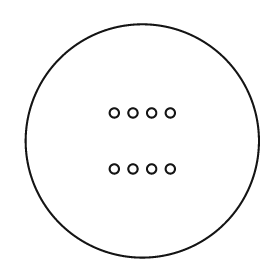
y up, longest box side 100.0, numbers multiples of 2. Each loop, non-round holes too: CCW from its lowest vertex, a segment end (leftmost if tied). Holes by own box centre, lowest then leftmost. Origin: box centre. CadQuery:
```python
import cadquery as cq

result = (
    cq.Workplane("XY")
    .moveTo(0.0, 0.0)
    .circle(50.0)
    .moveTo(-12.0, -12.0)
    .circle(2.0)
    .moveTo(-4.0, -12.0)
    .circle(2.0)
    .moveTo(4.0, -12.0)
    .circle(2.0)
    .moveTo(12.0, -12.0)
    .circle(2.0)
    .moveTo(-12.0, 12.0)
    .circle(2.0)
    .moveTo(-4.0, 12.0)
    .circle(2.0)
    .moveTo(4.0, 12.0)
    .circle(2.0)
    .moveTo(12.0, 12.0)
    .circle(2.0)
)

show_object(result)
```